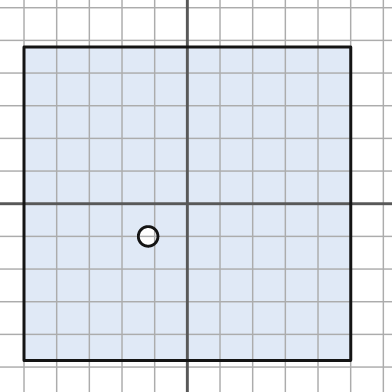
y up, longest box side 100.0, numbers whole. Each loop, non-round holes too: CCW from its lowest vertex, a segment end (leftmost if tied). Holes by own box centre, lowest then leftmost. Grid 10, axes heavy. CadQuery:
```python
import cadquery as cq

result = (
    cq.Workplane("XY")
    .moveTo(-50.0, -48.0)
    .lineTo(50.0, -48.0)
    .lineTo(50.0, 48.0)
    .lineTo(-50.0, 48.0)
    .close()
    .moveTo(-12.0, -10.0)
    .circle(3.0)
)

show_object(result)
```